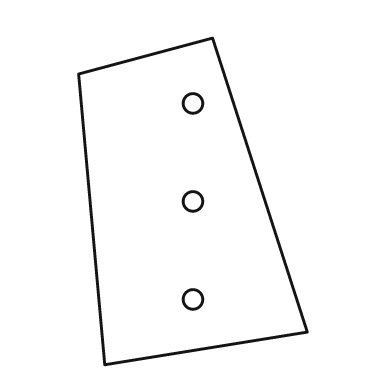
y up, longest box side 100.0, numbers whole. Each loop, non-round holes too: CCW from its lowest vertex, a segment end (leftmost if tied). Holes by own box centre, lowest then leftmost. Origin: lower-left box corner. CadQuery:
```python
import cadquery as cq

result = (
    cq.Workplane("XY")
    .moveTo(8.0, 0.0)
    .lineTo(70.0, 10.0)
    .lineTo(41.0, 100.0)
    .lineTo(0.0, 89.0)
    .close()
    .moveTo(35.0, 20.0)
    .circle(3.0)
    .moveTo(35.0, 50.0)
    .circle(3.0)
    .moveTo(35.0, 80.0)
    .circle(3.0)
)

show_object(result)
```